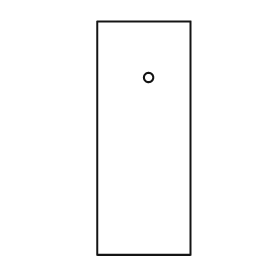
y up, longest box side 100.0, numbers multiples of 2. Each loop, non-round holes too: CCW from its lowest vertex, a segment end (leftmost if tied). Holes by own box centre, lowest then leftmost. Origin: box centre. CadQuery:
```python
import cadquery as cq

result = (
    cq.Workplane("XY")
    .moveTo(-20.0, -50.0)
    .lineTo(20.0, -50.0)
    .lineTo(20.0, 50.0)
    .lineTo(-20.0, 50.0)
    .close()
    .moveTo(2.0, 26.0)
    .circle(2.0)
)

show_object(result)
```